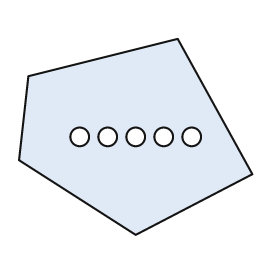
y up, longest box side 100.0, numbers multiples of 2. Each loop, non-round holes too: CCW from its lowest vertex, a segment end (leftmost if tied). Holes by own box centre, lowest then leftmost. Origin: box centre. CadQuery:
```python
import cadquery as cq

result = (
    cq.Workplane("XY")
    .moveTo(0.0, -42.0)
    .lineTo(50.0, -16.0)
    .lineTo(18.0, 42.0)
    .lineTo(-46.0, 26.0)
    .lineTo(-50.0, -10.0)
    .close()
    .moveTo(-24.0, 0.0)
    .circle(4.0)
    .moveTo(-12.0, 0.0)
    .circle(4.0)
    .moveTo(0.0, 0.0)
    .circle(4.0)
    .moveTo(12.0, 0.0)
    .circle(4.0)
    .moveTo(24.0, 0.0)
    .circle(4.0)
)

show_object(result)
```